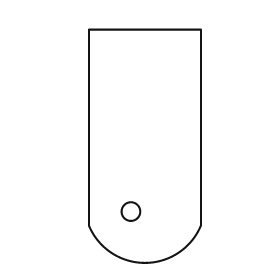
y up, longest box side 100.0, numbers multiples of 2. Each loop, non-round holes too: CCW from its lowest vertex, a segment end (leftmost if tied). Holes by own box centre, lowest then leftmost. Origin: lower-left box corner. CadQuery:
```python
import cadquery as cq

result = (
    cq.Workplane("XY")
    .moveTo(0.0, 16.0)
    .threePointArc((24.0, 0.0), (48.0, 16.0))
    .lineTo(48.0, 100.0)
    .lineTo(0.0, 100.0)
    .close()
    .moveTo(18.0, 22.0)
    .circle(4.0)
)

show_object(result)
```